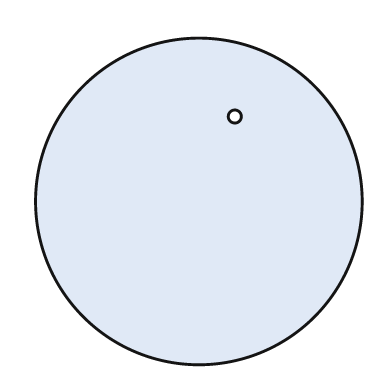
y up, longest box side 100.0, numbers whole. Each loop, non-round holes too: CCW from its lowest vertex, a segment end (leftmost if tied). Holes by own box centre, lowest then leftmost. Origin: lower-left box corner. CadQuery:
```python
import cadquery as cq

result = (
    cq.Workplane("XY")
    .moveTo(50.0, 50.0)
    .circle(50.0)
    .moveTo(61.0, 76.0)
    .circle(2.0)
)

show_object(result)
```